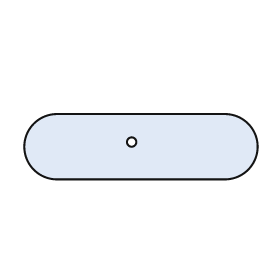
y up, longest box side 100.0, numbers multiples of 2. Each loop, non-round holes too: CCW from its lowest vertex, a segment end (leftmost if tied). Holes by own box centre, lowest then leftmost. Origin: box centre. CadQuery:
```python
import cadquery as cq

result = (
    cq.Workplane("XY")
    .moveTo(-36.0, -14.0)
    .lineTo(36.0, -14.0)
    .threePointArc((50.0, 0.0), (36.0, 14.0))
    .lineTo(-36.0, 14.0)
    .threePointArc((-50.0, 0.0), (-36.0, -14.0))
    .close()
    .moveTo(-4.0, 2.0)
    .circle(2.0)
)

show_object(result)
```